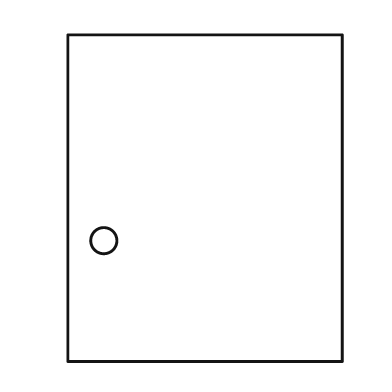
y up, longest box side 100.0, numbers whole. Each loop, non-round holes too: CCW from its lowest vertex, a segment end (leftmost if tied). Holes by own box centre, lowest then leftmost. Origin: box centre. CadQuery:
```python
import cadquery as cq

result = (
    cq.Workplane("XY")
    .moveTo(-42.0, -50.0)
    .lineTo(42.0, -50.0)
    .lineTo(42.0, 50.0)
    .lineTo(-42.0, 50.0)
    .close()
    .moveTo(-31.0, -13.0)
    .circle(4.0)
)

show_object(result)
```